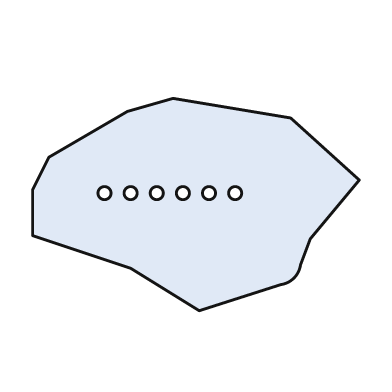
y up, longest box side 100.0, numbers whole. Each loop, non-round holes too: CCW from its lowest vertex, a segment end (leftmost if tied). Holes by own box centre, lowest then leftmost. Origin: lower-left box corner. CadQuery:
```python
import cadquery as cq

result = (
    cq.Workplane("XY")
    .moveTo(51.0, 0.0)
    .lineTo(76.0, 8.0)
    .threePointArc((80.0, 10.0), (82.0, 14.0))
    .lineTo(85.0, 22.0)
    .lineTo(100.0, 40.0)
    .lineTo(79.0, 59.0)
    .lineTo(43.0, 65.0)
    .lineTo(29.0, 61.0)
    .lineTo(5.0, 47.0)
    .lineTo(0.0, 37.0)
    .lineTo(0.0, 23.0)
    .lineTo(30.0, 13.0)
    .close()
    .moveTo(22.0, 36.0)
    .circle(2.0)
    .moveTo(30.0, 36.0)
    .circle(2.0)
    .moveTo(38.0, 36.0)
    .circle(2.0)
    .moveTo(46.0, 36.0)
    .circle(2.0)
    .moveTo(54.0, 36.0)
    .circle(2.0)
    .moveTo(62.0, 36.0)
    .circle(2.0)
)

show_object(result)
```